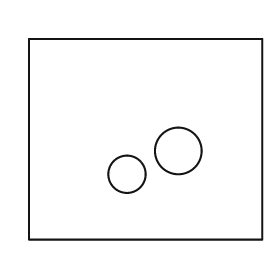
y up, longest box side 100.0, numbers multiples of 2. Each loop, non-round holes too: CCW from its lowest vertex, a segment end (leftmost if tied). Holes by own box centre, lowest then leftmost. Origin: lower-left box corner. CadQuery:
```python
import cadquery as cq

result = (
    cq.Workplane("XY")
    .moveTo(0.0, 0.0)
    .lineTo(100.0, 0.0)
    .lineTo(100.0, 86.0)
    .lineTo(0.0, 86.0)
    .close()
    .moveTo(42.0, 28.0)
    .circle(8.0)
    .moveTo(64.0, 38.0)
    .circle(10.0)
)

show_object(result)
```